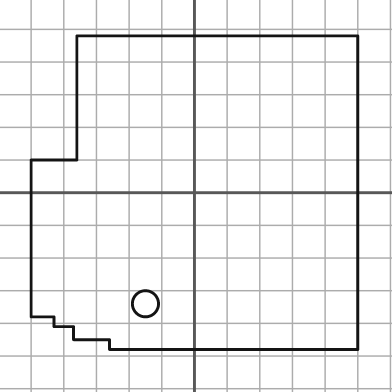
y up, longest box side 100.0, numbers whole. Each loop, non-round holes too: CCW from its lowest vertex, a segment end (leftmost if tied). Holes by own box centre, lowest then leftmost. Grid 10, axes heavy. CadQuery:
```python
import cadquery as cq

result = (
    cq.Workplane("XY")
    .moveTo(-26.0, -48.0)
    .lineTo(50.0, -48.0)
    .lineTo(50.0, 48.0)
    .lineTo(-36.0, 48.0)
    .lineTo(-36.0, 10.0)
    .lineTo(-50.0, 10.0)
    .lineTo(-50.0, -38.0)
    .lineTo(-43.0, -38.0)
    .lineTo(-43.0, -41.0)
    .lineTo(-37.0, -41.0)
    .lineTo(-37.0, -45.0)
    .lineTo(-26.0, -45.0)
    .close()
    .moveTo(-15.0, -34.0)
    .circle(4.0)
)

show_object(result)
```